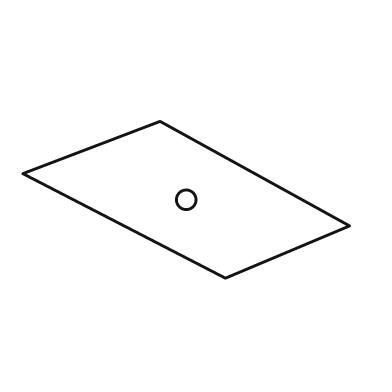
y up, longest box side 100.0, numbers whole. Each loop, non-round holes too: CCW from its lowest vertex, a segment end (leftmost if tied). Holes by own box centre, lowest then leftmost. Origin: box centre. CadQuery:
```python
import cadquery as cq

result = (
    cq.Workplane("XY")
    .moveTo(12.0, -24.0)
    .lineTo(50.0, -8.0)
    .lineTo(-8.0, 24.0)
    .lineTo(-50.0, 8.0)
    .close()
    .moveTo(0.0, 0.0)
    .circle(3.0)
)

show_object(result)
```